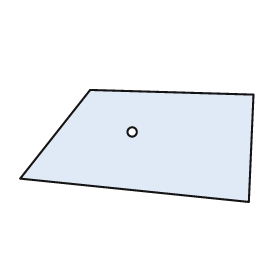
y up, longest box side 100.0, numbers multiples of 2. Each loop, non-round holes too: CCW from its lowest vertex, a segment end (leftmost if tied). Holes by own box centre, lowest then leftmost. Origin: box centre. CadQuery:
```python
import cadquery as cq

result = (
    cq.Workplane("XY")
    .moveTo(48.0, -24.0)
    .lineTo(50.0, 22.0)
    .lineTo(-20.0, 24.0)
    .lineTo(-50.0, -14.0)
    .close()
    .moveTo(-2.0, 6.0)
    .circle(2.0)
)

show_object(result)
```